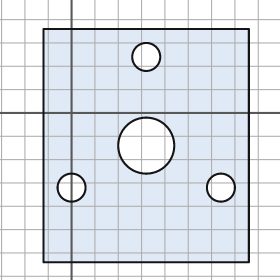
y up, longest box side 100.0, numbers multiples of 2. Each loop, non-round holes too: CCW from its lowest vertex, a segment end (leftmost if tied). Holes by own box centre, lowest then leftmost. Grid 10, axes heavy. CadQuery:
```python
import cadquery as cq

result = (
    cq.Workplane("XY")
    .moveTo(-12.0, -64.0)
    .lineTo(76.0, -64.0)
    .lineTo(76.0, 36.0)
    .lineTo(-12.0, 36.0)
    .close()
    .moveTo(0.0, -32.0)
    .circle(6.0)
    .moveTo(64.0, -32.0)
    .circle(6.0)
    .moveTo(32.0, -14.0)
    .circle(12.0)
    .moveTo(32.0, 24.0)
    .circle(6.0)
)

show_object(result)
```